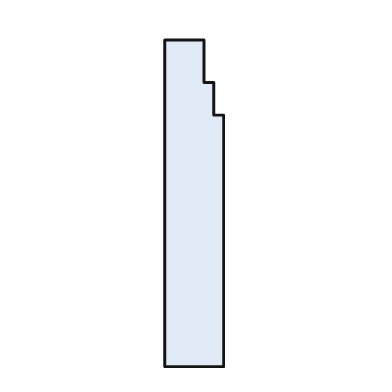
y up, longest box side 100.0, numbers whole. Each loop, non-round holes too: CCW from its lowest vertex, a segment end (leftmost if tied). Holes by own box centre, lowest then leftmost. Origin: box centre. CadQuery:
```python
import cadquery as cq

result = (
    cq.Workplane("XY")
    .moveTo(-9.0, -50.0)
    .lineTo(9.0, -50.0)
    .lineTo(9.0, 27.0)
    .lineTo(6.0, 27.0)
    .lineTo(6.0, 37.0)
    .lineTo(3.0, 37.0)
    .lineTo(3.0, 50.0)
    .lineTo(-9.0, 50.0)
    .close()
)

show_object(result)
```